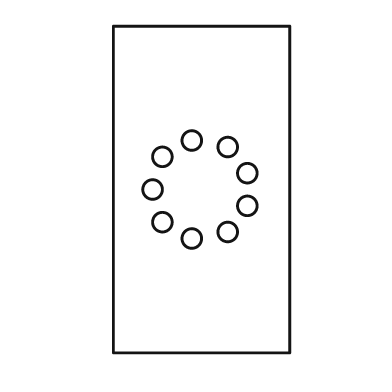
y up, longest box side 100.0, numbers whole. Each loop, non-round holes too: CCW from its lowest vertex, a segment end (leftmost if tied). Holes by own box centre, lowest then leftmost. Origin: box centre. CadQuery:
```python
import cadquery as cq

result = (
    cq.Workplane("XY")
    .moveTo(-27.0, -50.0)
    .lineTo(27.0, -50.0)
    .lineTo(27.0, 50.0)
    .lineTo(-27.0, 50.0)
    .close()
    .moveTo(-3.0, -15.0)
    .circle(3.0)
    .moveTo(8.0, -13.0)
    .circle(3.0)
    .moveTo(-12.0, -10.0)
    .circle(3.0)
    .moveTo(14.0, -5.0)
    .circle(3.0)
    .moveTo(-15.0, 0.0)
    .circle(3.0)
    .moveTo(14.0, 5.0)
    .circle(3.0)
    .moveTo(-12.0, 10.0)
    .circle(3.0)
    .moveTo(8.0, 13.0)
    .circle(3.0)
    .moveTo(-3.0, 15.0)
    .circle(3.0)
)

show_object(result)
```